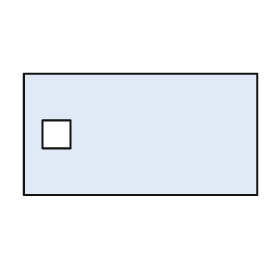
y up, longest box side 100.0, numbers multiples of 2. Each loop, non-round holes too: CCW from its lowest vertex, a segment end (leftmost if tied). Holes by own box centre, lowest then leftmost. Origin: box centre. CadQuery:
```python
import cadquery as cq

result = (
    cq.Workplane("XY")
    .moveTo(-50.0, -26.0)
    .lineTo(50.0, -26.0)
    .lineTo(50.0, 26.0)
    .lineTo(-50.0, 26.0)
    .close()
    .moveTo(-42.0, -6.0)
    .lineTo(-30.0, -6.0)
    .lineTo(-30.0, 6.0)
    .lineTo(-42.0, 6.0)
    .close()
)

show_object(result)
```